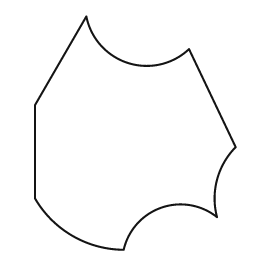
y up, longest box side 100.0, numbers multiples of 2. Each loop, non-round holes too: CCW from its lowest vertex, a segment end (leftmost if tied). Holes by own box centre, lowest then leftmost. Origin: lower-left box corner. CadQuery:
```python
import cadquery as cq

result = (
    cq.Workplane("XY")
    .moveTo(38.0, 0.0)
    .threePointArc((54.0, 18.0), (78.0, 14.0))
    .threePointArc((78.0, 30.0), (86.0, 44.0))
    .lineTo(66.0, 86.0)
    .threePointArc((40.0, 80.0), (22.0, 100.0))
    .lineTo(0.0, 62.0)
    .lineTo(0.0, 22.0)
    .threePointArc((16.0, 6.0), (38.0, 0.0))
    .close()
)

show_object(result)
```